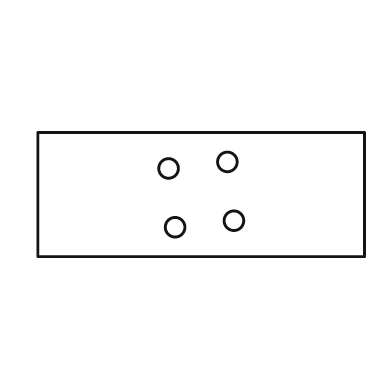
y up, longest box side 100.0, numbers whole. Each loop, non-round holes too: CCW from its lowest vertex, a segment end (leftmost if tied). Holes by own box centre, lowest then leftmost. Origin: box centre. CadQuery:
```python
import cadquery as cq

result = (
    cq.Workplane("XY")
    .moveTo(-50.0, -19.0)
    .lineTo(50.0, -19.0)
    .lineTo(50.0, 19.0)
    .lineTo(-50.0, 19.0)
    .close()
    .moveTo(-8.0, -10.0)
    .circle(3.0)
    .moveTo(10.0, -8.0)
    .circle(3.0)
    .moveTo(-10.0, 8.0)
    .circle(3.0)
    .moveTo(8.0, 10.0)
    .circle(3.0)
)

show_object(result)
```